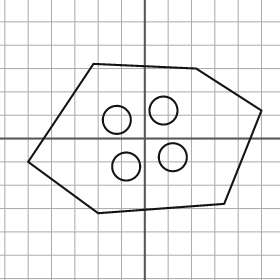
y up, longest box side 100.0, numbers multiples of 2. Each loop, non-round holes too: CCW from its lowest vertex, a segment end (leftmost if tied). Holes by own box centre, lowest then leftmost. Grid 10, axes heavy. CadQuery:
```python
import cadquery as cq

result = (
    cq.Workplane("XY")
    .moveTo(-20.0, -32.0)
    .lineTo(34.0, -28.0)
    .lineTo(50.0, 12.0)
    .lineTo(22.0, 30.0)
    .lineTo(-22.0, 32.0)
    .lineTo(-50.0, -10.0)
    .close()
    .moveTo(-8.0, -12.0)
    .circle(6.0)
    .moveTo(12.0, -8.0)
    .circle(6.0)
    .moveTo(-12.0, 8.0)
    .circle(6.0)
    .moveTo(8.0, 12.0)
    .circle(6.0)
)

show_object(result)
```